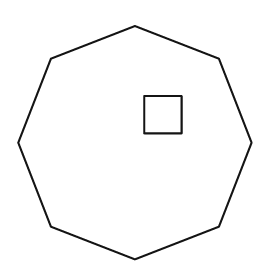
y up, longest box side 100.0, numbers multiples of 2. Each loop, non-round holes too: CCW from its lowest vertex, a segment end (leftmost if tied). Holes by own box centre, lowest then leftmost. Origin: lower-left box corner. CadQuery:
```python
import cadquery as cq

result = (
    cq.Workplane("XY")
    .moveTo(50.0, 0.0)
    .lineTo(86.0, 14.0)
    .lineTo(100.0, 50.0)
    .lineTo(86.0, 86.0)
    .lineTo(50.0, 100.0)
    .lineTo(14.0, 86.0)
    .lineTo(0.0, 50.0)
    .lineTo(14.0, 14.0)
    .close()
    .moveTo(54.0, 54.0)
    .lineTo(70.0, 54.0)
    .lineTo(70.0, 70.0)
    .lineTo(54.0, 70.0)
    .close()
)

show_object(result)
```